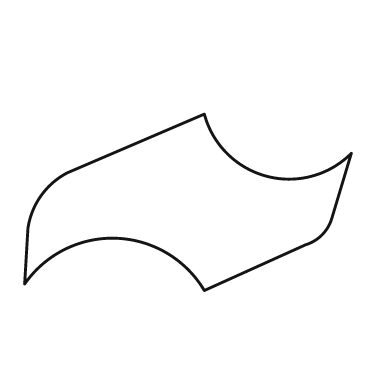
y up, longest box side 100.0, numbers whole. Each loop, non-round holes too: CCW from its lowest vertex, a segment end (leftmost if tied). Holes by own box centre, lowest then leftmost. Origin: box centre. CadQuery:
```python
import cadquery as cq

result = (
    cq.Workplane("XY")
    .moveTo(5.0, -27.0)
    .lineTo(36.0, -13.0)
    .threePointArc((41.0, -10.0), (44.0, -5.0))
    .lineTo(50.0, 15.0)
    .threePointArc((24.0, 8.0), (5.0, 27.0))
    .lineTo(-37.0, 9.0)
    .threePointArc((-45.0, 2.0), (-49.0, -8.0))
    .lineTo(-50.0, -25.0)
    .threePointArc((-22.0, -11.0), (5.0, -27.0))
    .close()
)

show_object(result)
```